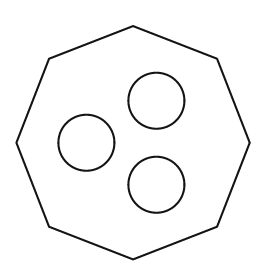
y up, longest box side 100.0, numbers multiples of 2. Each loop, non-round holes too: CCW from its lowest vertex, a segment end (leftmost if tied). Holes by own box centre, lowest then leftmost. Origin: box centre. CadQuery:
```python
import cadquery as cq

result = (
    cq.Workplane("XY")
    .moveTo(0.0, -50.0)
    .lineTo(36.0, -36.0)
    .lineTo(50.0, 0.0)
    .lineTo(36.0, 36.0)
    .lineTo(0.0, 50.0)
    .lineTo(-36.0, 36.0)
    .lineTo(-50.0, 0.0)
    .lineTo(-36.0, -36.0)
    .close()
    .moveTo(10.0, -18.0)
    .circle(12.0)
    .moveTo(-20.0, 0.0)
    .circle(12.0)
    .moveTo(10.0, 18.0)
    .circle(12.0)
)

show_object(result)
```